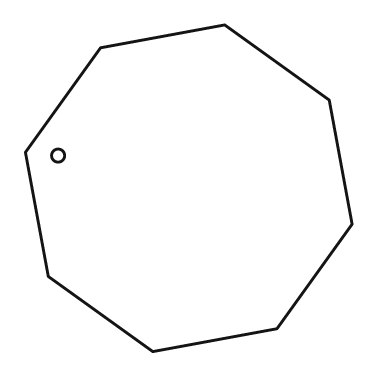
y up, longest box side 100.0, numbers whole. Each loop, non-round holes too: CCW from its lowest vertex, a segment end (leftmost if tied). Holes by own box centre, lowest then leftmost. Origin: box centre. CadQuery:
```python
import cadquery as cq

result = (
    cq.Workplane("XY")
    .moveTo(-11.0, -50.0)
    .lineTo(27.0, -43.0)
    .lineTo(50.0, -11.0)
    .lineTo(43.0, 27.0)
    .lineTo(11.0, 50.0)
    .lineTo(-27.0, 43.0)
    .lineTo(-50.0, 11.0)
    .lineTo(-43.0, -27.0)
    .close()
    .moveTo(-40.0, 10.0)
    .circle(2.0)
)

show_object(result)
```